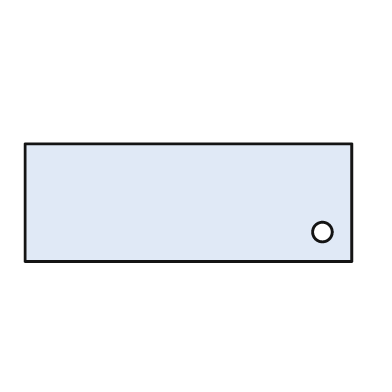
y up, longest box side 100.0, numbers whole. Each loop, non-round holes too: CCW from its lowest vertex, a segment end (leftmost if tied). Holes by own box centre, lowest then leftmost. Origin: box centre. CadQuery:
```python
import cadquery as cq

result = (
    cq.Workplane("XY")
    .moveTo(-50.0, -18.0)
    .lineTo(50.0, -18.0)
    .lineTo(50.0, 18.0)
    .lineTo(-50.0, 18.0)
    .close()
    .moveTo(41.0, -9.0)
    .circle(3.0)
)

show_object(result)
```